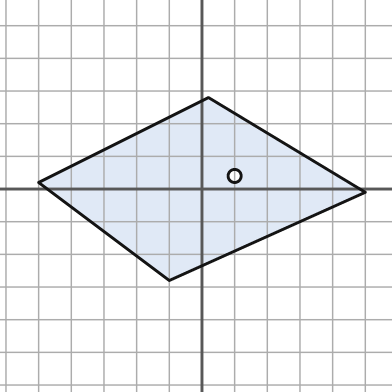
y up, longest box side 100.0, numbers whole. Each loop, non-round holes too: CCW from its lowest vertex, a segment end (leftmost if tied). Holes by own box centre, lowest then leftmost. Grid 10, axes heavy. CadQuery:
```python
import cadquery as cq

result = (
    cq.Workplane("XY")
    .moveTo(-10.0, -28.0)
    .lineTo(50.0, -1.0)
    .lineTo(2.0, 28.0)
    .lineTo(-50.0, 2.0)
    .close()
    .moveTo(10.0, 4.0)
    .circle(2.0)
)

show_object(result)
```